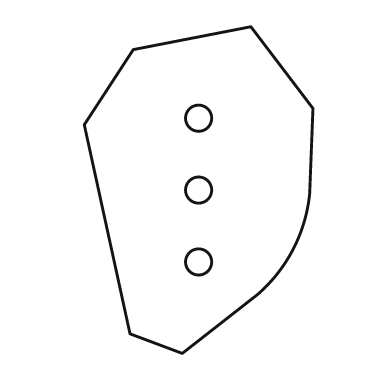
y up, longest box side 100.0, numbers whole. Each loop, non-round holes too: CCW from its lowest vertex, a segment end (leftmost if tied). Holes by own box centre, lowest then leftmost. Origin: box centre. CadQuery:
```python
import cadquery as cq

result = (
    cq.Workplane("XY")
    .moveTo(-5.0, -50.0)
    .lineTo(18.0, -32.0)
    .threePointArc((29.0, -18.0), (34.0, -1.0))
    .lineTo(35.0, 25.0)
    .lineTo(16.0, 50.0)
    .lineTo(-20.0, 43.0)
    .lineTo(-35.0, 20.0)
    .lineTo(-21.0, -44.0)
    .close()
    .moveTo(0.0, -22.0)
    .circle(4.0)
    .moveTo(0.0, 0.0)
    .circle(4.0)
    .moveTo(0.0, 22.0)
    .circle(4.0)
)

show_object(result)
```